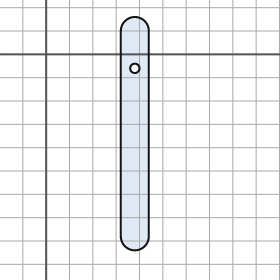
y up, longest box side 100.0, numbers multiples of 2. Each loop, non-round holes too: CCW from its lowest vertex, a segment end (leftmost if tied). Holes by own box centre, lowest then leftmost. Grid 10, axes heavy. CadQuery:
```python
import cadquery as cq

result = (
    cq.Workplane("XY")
    .moveTo(32.0, -78.0)
    .threePointArc((38.0, -84.0), (44.0, -78.0))
    .lineTo(44.0, 10.0)
    .threePointArc((38.0, 16.0), (32.0, 10.0))
    .close()
    .moveTo(38.0, -6.0)
    .circle(2.0)
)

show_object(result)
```